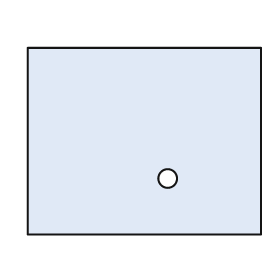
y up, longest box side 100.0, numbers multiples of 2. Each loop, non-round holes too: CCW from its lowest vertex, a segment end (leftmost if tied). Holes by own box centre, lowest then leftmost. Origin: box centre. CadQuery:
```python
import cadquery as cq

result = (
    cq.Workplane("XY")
    .moveTo(-50.0, -40.0)
    .lineTo(50.0, -40.0)
    .lineTo(50.0, 40.0)
    .lineTo(-50.0, 40.0)
    .close()
    .moveTo(10.0, -16.0)
    .circle(4.0)
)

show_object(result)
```